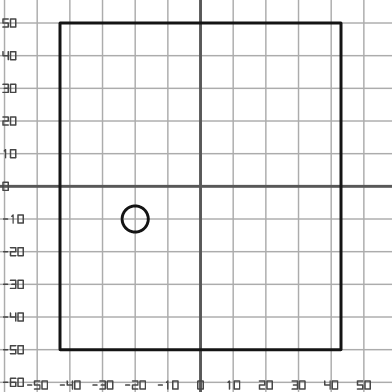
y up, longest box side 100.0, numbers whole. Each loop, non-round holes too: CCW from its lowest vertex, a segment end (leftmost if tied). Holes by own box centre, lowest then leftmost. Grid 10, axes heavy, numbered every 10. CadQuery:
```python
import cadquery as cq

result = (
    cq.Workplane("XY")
    .moveTo(-43.0, -50.0)
    .lineTo(43.0, -50.0)
    .lineTo(43.0, 50.0)
    .lineTo(-43.0, 50.0)
    .close()
    .moveTo(-20.0, -10.0)
    .circle(4.0)
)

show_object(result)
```